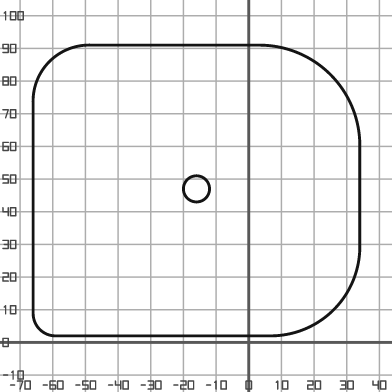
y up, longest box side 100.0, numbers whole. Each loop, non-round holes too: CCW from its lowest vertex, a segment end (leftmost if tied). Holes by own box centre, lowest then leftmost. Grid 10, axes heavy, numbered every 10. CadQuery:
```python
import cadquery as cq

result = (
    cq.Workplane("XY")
    .moveTo(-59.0, 2.0)
    .lineTo(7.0, 2.0)
    .threePointArc((26.0, 10.0), (34.0, 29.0))
    .lineTo(34.0, 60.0)
    .threePointArc((25.0, 82.0), (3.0, 91.0))
    .lineTo(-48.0, 91.0)
    .threePointArc((-61.0, 86.0), (-66.0, 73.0))
    .lineTo(-66.0, 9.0)
    .threePointArc((-64.0, 4.0), (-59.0, 2.0))
    .close()
    .moveTo(-16.0, 47.0)
    .circle(4.0)
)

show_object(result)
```